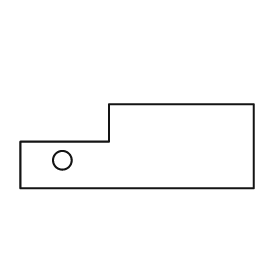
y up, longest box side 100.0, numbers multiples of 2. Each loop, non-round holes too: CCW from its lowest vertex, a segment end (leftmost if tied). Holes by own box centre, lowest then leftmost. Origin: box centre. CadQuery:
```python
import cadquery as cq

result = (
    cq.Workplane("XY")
    .moveTo(-50.0, -18.0)
    .lineTo(50.0, -18.0)
    .lineTo(50.0, 18.0)
    .lineTo(-12.0, 18.0)
    .lineTo(-12.0, 2.0)
    .lineTo(-50.0, 2.0)
    .close()
    .moveTo(-32.0, -6.0)
    .circle(4.0)
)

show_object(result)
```